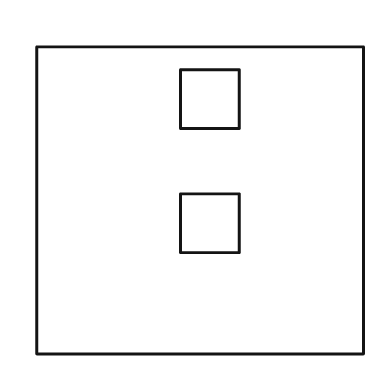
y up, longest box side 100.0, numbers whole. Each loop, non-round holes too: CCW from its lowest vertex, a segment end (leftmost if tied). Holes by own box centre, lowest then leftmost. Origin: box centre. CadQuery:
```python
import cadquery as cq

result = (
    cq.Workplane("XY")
    .moveTo(-50.0, -47.0)
    .lineTo(50.0, -47.0)
    .lineTo(50.0, 47.0)
    .lineTo(-50.0, 47.0)
    .close()
    .moveTo(-6.0, -16.0)
    .lineTo(12.0, -16.0)
    .lineTo(12.0, 2.0)
    .lineTo(-6.0, 2.0)
    .close()
    .moveTo(-6.0, 22.0)
    .lineTo(12.0, 22.0)
    .lineTo(12.0, 40.0)
    .lineTo(-6.0, 40.0)
    .close()
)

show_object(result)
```